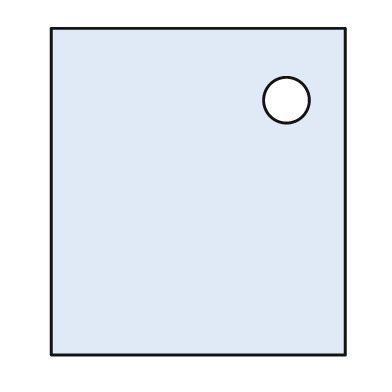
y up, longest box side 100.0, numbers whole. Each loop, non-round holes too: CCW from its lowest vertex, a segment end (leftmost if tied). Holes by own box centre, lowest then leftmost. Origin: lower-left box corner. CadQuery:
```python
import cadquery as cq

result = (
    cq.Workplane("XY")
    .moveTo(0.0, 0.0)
    .lineTo(90.0, 0.0)
    .lineTo(90.0, 100.0)
    .lineTo(0.0, 100.0)
    .close()
    .moveTo(72.0, 78.0)
    .circle(7.0)
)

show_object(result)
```